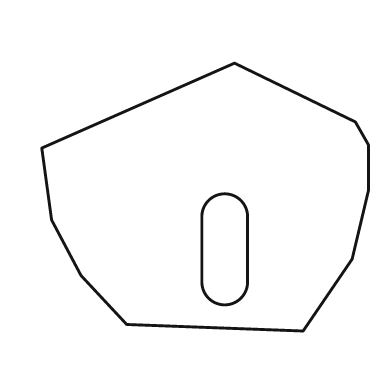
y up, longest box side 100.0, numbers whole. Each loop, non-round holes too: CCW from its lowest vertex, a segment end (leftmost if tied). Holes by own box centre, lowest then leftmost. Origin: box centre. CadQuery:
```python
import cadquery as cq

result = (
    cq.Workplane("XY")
    .moveTo(30.0, -41.0)
    .lineTo(45.0, -19.0)
    .lineTo(50.0, 2.0)
    .lineTo(50.0, 16.0)
    .lineTo(46.0, 23.0)
    .lineTo(9.0, 41.0)
    .lineTo(-50.0, 15.0)
    .lineTo(-47.0, -7.0)
    .lineTo(-38.0, -24.0)
    .lineTo(-24.0, -39.0)
    .close()
    .moveTo(-1.0, -26.0)
    .threePointArc((6.0, -33.0), (13.0, -26.0))
    .lineTo(13.0, -6.0)
    .threePointArc((6.0, 1.0), (-1.0, -6.0))
    .close()
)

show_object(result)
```